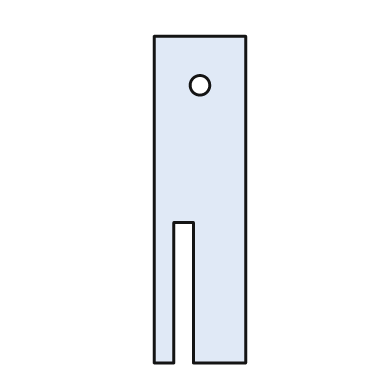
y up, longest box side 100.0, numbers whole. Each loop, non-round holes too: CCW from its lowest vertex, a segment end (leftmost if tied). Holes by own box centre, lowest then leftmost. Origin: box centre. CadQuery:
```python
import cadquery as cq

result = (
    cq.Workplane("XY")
    .moveTo(-14.0, -50.0)
    .lineTo(-8.0, -50.0)
    .lineTo(-8.0, -7.0)
    .lineTo(-2.0, -7.0)
    .lineTo(-2.0, -50.0)
    .lineTo(14.0, -50.0)
    .lineTo(14.0, 50.0)
    .lineTo(-14.0, 50.0)
    .close()
    .moveTo(0.0, 35.0)
    .circle(3.0)
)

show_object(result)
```